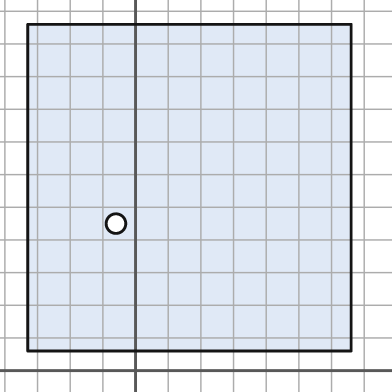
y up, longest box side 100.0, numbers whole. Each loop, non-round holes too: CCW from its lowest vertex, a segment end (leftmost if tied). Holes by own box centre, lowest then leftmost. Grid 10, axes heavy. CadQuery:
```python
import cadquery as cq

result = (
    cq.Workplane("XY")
    .moveTo(-33.0, 6.0)
    .lineTo(66.0, 6.0)
    .lineTo(66.0, 106.0)
    .lineTo(-33.0, 106.0)
    .close()
    .moveTo(-6.0, 45.0)
    .circle(3.0)
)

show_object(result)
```